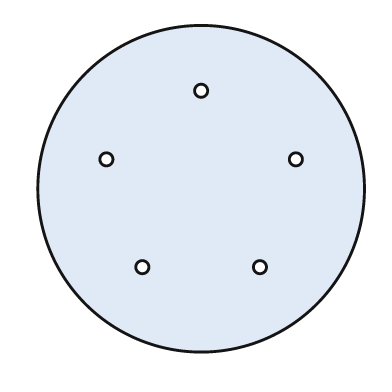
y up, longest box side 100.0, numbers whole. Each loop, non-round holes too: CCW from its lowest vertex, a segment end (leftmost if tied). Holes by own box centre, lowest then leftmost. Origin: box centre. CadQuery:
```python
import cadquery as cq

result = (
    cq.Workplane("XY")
    .moveTo(0.0, 0.0)
    .circle(50.0)
    .moveTo(-18.0, -24.0)
    .circle(2.0)
    .moveTo(18.0, -24.0)
    .circle(2.0)
    .moveTo(-29.0, 9.0)
    .circle(2.0)
    .moveTo(29.0, 9.0)
    .circle(2.0)
    .moveTo(0.0, 30.0)
    .circle(2.0)
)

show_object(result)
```